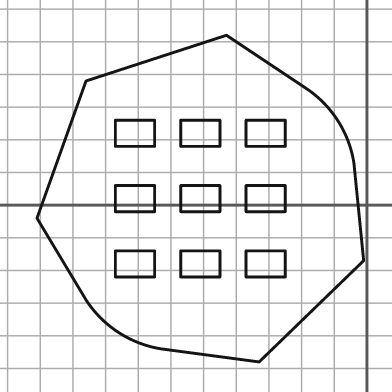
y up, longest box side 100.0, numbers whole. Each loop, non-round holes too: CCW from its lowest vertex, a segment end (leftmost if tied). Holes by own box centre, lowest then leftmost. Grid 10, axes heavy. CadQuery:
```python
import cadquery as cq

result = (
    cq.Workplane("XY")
    .moveTo(-33.0, -48.0)
    .lineTo(-1.0, -17.0)
    .lineTo(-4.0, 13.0)
    .threePointArc((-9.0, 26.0), (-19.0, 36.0))
    .lineTo(-43.0, 52.0)
    .lineTo(-86.0, 38.0)
    .lineTo(-101.0, -4.0)
    .lineTo(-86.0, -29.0)
    .threePointArc((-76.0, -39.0), (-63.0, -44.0))
    .close()
    .moveTo(-77.0, -22.0)
    .lineTo(-65.0, -22.0)
    .lineTo(-65.0, -14.0)
    .lineTo(-77.0, -14.0)
    .close()
    .moveTo(-57.0, -22.0)
    .lineTo(-45.0, -22.0)
    .lineTo(-45.0, -14.0)
    .lineTo(-57.0, -14.0)
    .close()
    .moveTo(-37.0, -22.0)
    .lineTo(-25.0, -22.0)
    .lineTo(-25.0, -14.0)
    .lineTo(-37.0, -14.0)
    .close()
    .moveTo(-77.0, -2.0)
    .lineTo(-65.0, -2.0)
    .lineTo(-65.0, 6.0)
    .lineTo(-77.0, 6.0)
    .close()
    .moveTo(-57.0, -2.0)
    .lineTo(-45.0, -2.0)
    .lineTo(-45.0, 6.0)
    .lineTo(-57.0, 6.0)
    .close()
    .moveTo(-37.0, -2.0)
    .lineTo(-25.0, -2.0)
    .lineTo(-25.0, 6.0)
    .lineTo(-37.0, 6.0)
    .close()
    .moveTo(-77.0, 18.0)
    .lineTo(-65.0, 18.0)
    .lineTo(-65.0, 26.0)
    .lineTo(-77.0, 26.0)
    .close()
    .moveTo(-57.0, 18.0)
    .lineTo(-45.0, 18.0)
    .lineTo(-45.0, 26.0)
    .lineTo(-57.0, 26.0)
    .close()
    .moveTo(-37.0, 18.0)
    .lineTo(-25.0, 18.0)
    .lineTo(-25.0, 26.0)
    .lineTo(-37.0, 26.0)
    .close()
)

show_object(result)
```